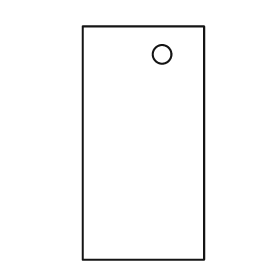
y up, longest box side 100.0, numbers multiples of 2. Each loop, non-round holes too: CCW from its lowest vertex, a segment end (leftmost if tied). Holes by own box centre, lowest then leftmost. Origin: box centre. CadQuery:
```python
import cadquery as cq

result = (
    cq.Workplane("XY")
    .moveTo(-26.0, -50.0)
    .lineTo(26.0, -50.0)
    .lineTo(26.0, 50.0)
    .lineTo(-26.0, 50.0)
    .close()
    .moveTo(8.0, 38.0)
    .circle(4.0)
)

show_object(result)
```